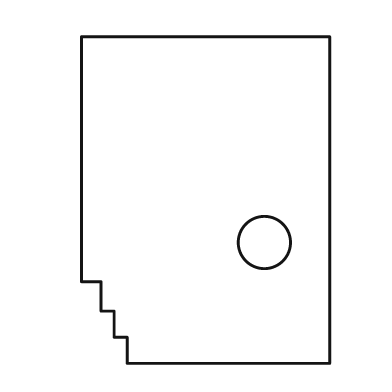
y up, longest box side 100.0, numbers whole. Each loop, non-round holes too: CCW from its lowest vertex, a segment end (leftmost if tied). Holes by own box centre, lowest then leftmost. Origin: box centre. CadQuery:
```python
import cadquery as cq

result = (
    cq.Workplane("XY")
    .moveTo(-24.0, -50.0)
    .lineTo(38.0, -50.0)
    .lineTo(38.0, 50.0)
    .lineTo(-38.0, 50.0)
    .lineTo(-38.0, -25.0)
    .lineTo(-32.0, -25.0)
    .lineTo(-32.0, -34.0)
    .lineTo(-28.0, -34.0)
    .lineTo(-28.0, -42.0)
    .lineTo(-24.0, -42.0)
    .close()
    .moveTo(18.0, -13.0)
    .circle(8.0)
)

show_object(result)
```